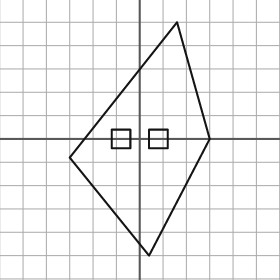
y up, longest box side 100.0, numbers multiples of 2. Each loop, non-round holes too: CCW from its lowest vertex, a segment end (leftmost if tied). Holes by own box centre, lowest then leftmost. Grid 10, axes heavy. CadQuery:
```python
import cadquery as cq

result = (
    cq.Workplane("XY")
    .moveTo(4.0, -50.0)
    .lineTo(30.0, 0.0)
    .lineTo(16.0, 50.0)
    .lineTo(-30.0, -8.0)
    .close()
    .moveTo(-12.0, -4.0)
    .lineTo(-4.0, -4.0)
    .lineTo(-4.0, 4.0)
    .lineTo(-12.0, 4.0)
    .close()
    .moveTo(4.0, -4.0)
    .lineTo(12.0, -4.0)
    .lineTo(12.0, 4.0)
    .lineTo(4.0, 4.0)
    .close()
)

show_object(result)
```